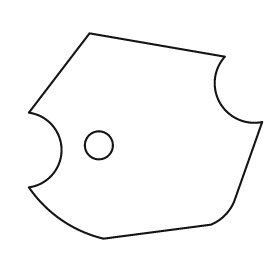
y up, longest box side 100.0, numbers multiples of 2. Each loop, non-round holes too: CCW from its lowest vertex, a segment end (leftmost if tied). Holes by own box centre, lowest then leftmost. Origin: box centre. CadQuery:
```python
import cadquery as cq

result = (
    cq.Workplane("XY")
    .moveTo(-18.0, -44.0)
    .lineTo(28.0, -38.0)
    .threePointArc((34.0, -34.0), (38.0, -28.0))
    .lineTo(50.0, 6.0)
    .threePointArc((32.0, 14.0), (34.0, 34.0))
    .lineTo(-24.0, 44.0)
    .lineTo(-50.0, 10.0)
    .threePointArc((-36.0, -6.0), (-50.0, -22.0))
    .threePointArc((-36.0, -36.0), (-18.0, -44.0))
    .close()
    .moveTo(-20.0, -4.0)
    .circle(6.0)
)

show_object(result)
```